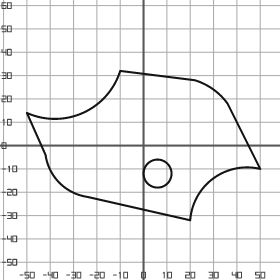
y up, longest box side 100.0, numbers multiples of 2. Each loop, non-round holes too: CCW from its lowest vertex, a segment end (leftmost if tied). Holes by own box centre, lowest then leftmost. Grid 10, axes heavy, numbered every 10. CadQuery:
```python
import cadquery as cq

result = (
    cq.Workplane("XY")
    .moveTo(20.0, -32.0)
    .threePointArc((30.0, -14.0), (50.0, -10.0))
    .lineTo(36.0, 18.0)
    .threePointArc((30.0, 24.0), (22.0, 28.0))
    .lineTo(-10.0, 32.0)
    .threePointArc((-26.0, 14.0), (-50.0, 14.0))
    .lineTo(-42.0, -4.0)
    .threePointArc((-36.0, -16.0), (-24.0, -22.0))
    .close()
    .moveTo(6.0, -12.0)
    .circle(6.0)
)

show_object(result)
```